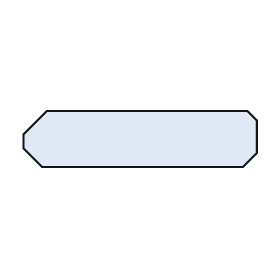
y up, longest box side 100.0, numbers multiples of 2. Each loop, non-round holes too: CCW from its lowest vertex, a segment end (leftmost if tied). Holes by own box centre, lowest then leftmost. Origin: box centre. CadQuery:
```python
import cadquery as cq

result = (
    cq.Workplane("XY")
    .moveTo(-42.0, -12.0)
    .lineTo(44.0, -12.0)
    .lineTo(50.0, -6.0)
    .lineTo(50.0, 8.0)
    .lineTo(46.0, 12.0)
    .lineTo(-40.0, 12.0)
    .lineTo(-50.0, 2.0)
    .lineTo(-50.0, -4.0)
    .close()
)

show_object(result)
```